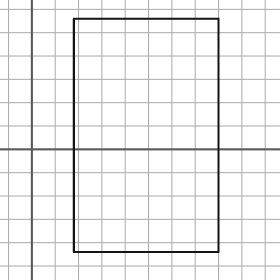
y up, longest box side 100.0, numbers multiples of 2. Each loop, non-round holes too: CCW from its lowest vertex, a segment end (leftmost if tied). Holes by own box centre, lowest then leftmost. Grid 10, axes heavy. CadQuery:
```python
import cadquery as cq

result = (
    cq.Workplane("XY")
    .moveTo(18.0, -44.0)
    .lineTo(80.0, -44.0)
    .lineTo(80.0, 56.0)
    .lineTo(18.0, 56.0)
    .close()
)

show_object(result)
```